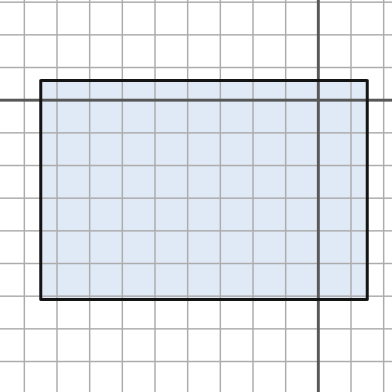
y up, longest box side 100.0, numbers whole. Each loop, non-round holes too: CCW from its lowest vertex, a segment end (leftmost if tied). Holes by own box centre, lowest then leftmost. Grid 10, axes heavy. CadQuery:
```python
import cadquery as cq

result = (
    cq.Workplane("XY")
    .moveTo(-85.0, -61.0)
    .lineTo(15.0, -61.0)
    .lineTo(15.0, 6.0)
    .lineTo(-85.0, 6.0)
    .close()
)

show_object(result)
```